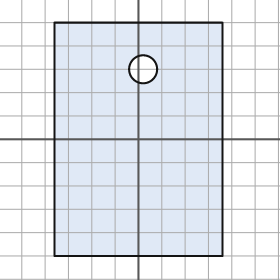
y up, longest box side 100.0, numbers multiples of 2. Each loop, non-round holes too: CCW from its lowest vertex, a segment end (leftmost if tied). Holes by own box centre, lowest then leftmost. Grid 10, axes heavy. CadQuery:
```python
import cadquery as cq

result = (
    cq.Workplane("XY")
    .moveTo(-36.0, -50.0)
    .lineTo(36.0, -50.0)
    .lineTo(36.0, 50.0)
    .lineTo(-36.0, 50.0)
    .close()
    .moveTo(2.0, 30.0)
    .circle(6.0)
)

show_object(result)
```